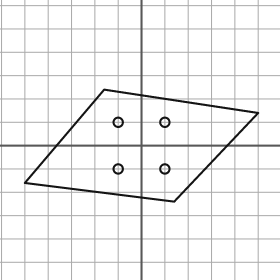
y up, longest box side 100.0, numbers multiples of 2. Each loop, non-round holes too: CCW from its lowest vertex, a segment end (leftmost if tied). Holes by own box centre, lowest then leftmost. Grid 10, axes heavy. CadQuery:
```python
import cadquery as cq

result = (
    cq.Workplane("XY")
    .moveTo(14.0, -24.0)
    .lineTo(50.0, 14.0)
    .lineTo(-16.0, 24.0)
    .lineTo(-50.0, -16.0)
    .close()
    .moveTo(-10.0, -10.0)
    .circle(2.0)
    .moveTo(10.0, -10.0)
    .circle(2.0)
    .moveTo(-10.0, 10.0)
    .circle(2.0)
    .moveTo(10.0, 10.0)
    .circle(2.0)
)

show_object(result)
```